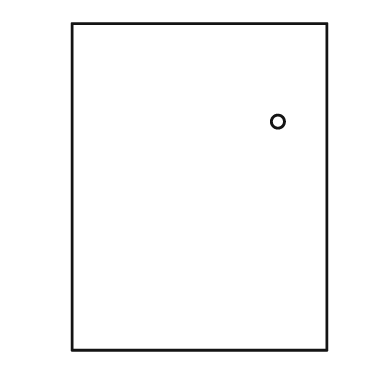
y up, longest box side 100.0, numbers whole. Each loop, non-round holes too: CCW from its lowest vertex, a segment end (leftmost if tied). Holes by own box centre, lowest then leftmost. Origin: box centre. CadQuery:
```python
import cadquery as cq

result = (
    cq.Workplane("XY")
    .moveTo(-39.0, -50.0)
    .lineTo(39.0, -50.0)
    .lineTo(39.0, 50.0)
    .lineTo(-39.0, 50.0)
    .close()
    .moveTo(24.0, 20.0)
    .circle(2.0)
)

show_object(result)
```